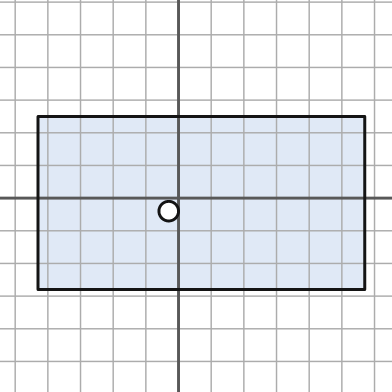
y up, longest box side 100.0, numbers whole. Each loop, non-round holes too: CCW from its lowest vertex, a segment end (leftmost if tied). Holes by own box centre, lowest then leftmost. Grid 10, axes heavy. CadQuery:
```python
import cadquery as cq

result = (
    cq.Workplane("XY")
    .moveTo(-43.0, -28.0)
    .lineTo(57.0, -28.0)
    .lineTo(57.0, 25.0)
    .lineTo(-43.0, 25.0)
    .close()
    .moveTo(-3.0, -4.0)
    .circle(3.0)
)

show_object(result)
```